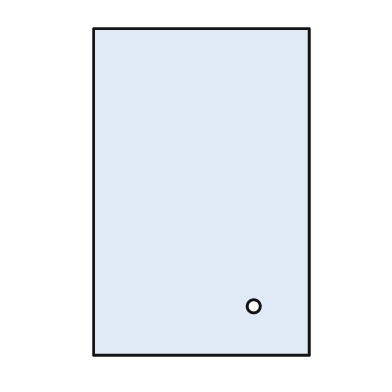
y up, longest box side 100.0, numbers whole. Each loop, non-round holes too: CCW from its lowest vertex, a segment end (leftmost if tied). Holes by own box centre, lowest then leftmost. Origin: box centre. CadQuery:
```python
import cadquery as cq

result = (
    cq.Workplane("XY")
    .moveTo(-33.0, -50.0)
    .lineTo(33.0, -50.0)
    .lineTo(33.0, 50.0)
    .lineTo(-33.0, 50.0)
    .close()
    .moveTo(16.0, -35.0)
    .circle(2.0)
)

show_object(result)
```